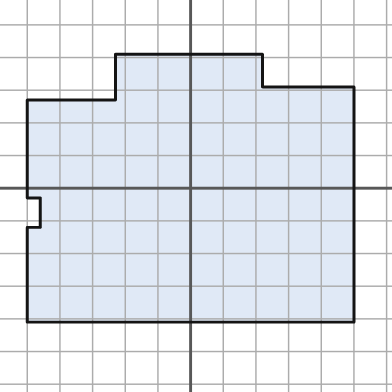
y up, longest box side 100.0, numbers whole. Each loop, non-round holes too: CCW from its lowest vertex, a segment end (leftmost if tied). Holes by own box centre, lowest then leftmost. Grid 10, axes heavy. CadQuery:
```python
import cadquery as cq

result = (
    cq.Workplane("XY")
    .moveTo(-50.0, -41.0)
    .lineTo(50.0, -41.0)
    .lineTo(50.0, 31.0)
    .lineTo(22.0, 31.0)
    .lineTo(22.0, 41.0)
    .lineTo(-23.0, 41.0)
    .lineTo(-23.0, 27.0)
    .lineTo(-50.0, 27.0)
    .lineTo(-50.0, -3.0)
    .lineTo(-46.0, -3.0)
    .lineTo(-46.0, -12.0)
    .lineTo(-50.0, -12.0)
    .close()
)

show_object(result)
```